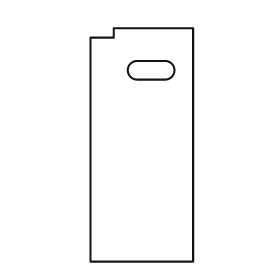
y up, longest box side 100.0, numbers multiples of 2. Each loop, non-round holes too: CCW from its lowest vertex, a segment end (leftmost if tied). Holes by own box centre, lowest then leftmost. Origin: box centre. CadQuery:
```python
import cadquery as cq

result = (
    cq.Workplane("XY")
    .moveTo(-22.0, -50.0)
    .lineTo(22.0, -50.0)
    .lineTo(22.0, 50.0)
    .lineTo(-12.0, 50.0)
    .lineTo(-12.0, 46.0)
    .lineTo(-22.0, 46.0)
    .close()
    .moveTo(-2.0, 28.0)
    .lineTo(10.0, 28.0)
    .threePointArc((14.0, 32.0), (10.0, 36.0))
    .lineTo(-2.0, 36.0)
    .threePointArc((-6.0, 32.0), (-2.0, 28.0))
    .close()
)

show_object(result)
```